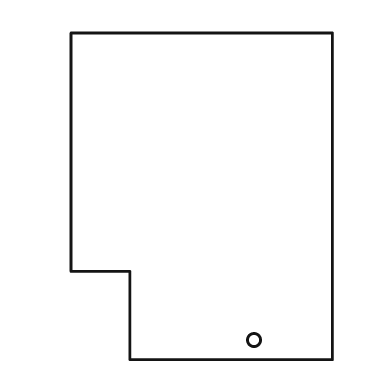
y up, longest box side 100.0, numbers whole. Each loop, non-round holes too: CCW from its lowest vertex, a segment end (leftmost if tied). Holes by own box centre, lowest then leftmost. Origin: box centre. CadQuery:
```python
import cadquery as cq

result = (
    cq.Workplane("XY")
    .moveTo(-22.0, -50.0)
    .lineTo(40.0, -50.0)
    .lineTo(40.0, 50.0)
    .lineTo(-40.0, 50.0)
    .lineTo(-40.0, -23.0)
    .lineTo(-22.0, -23.0)
    .close()
    .moveTo(16.0, -44.0)
    .circle(2.0)
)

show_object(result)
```